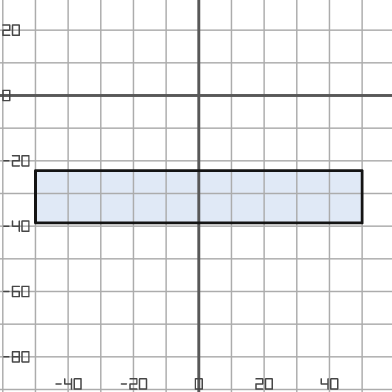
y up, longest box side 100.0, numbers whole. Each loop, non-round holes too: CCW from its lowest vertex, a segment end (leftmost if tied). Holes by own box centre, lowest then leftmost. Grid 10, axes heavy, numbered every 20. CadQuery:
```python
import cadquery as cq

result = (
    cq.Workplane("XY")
    .moveTo(-50.0, -39.0)
    .lineTo(50.0, -39.0)
    .lineTo(50.0, -23.0)
    .lineTo(-50.0, -23.0)
    .close()
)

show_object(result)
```